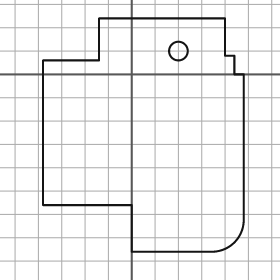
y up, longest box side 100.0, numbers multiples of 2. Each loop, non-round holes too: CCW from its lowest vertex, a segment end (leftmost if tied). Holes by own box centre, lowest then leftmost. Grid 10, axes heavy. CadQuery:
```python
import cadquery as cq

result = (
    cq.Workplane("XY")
    .moveTo(0.0, -76.0)
    .lineTo(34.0, -76.0)
    .threePointArc((44.0, -72.0), (48.0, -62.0))
    .lineTo(48.0, 0.0)
    .lineTo(44.0, 0.0)
    .lineTo(44.0, 8.0)
    .lineTo(40.0, 8.0)
    .lineTo(40.0, 24.0)
    .lineTo(-14.0, 24.0)
    .lineTo(-14.0, 6.0)
    .lineTo(-38.0, 6.0)
    .lineTo(-38.0, -56.0)
    .lineTo(0.0, -56.0)
    .close()
    .moveTo(20.0, 10.0)
    .circle(4.0)
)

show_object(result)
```